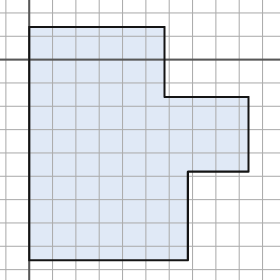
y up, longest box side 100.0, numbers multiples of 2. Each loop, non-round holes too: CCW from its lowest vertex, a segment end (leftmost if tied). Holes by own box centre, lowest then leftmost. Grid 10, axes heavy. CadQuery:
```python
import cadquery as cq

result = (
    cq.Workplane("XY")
    .moveTo(0.0, -86.0)
    .lineTo(68.0, -86.0)
    .lineTo(68.0, -48.0)
    .lineTo(94.0, -48.0)
    .lineTo(94.0, -16.0)
    .lineTo(58.0, -16.0)
    .lineTo(58.0, 14.0)
    .lineTo(0.0, 14.0)
    .close()
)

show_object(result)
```